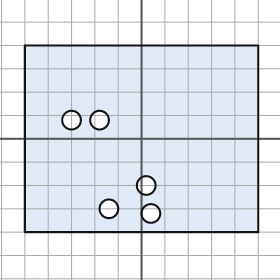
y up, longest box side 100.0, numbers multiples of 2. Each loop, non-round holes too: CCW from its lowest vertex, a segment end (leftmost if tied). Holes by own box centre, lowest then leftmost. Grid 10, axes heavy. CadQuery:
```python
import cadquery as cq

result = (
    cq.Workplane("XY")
    .moveTo(-50.0, -40.0)
    .lineTo(50.0, -40.0)
    .lineTo(50.0, 40.0)
    .lineTo(-50.0, 40.0)
    .close()
    .moveTo(4.0, -32.0)
    .circle(4.0)
    .moveTo(-14.0, -30.0)
    .circle(4.0)
    .moveTo(2.0, -20.0)
    .circle(4.0)
    .moveTo(-30.0, 8.0)
    .circle(4.0)
    .moveTo(-18.0, 8.0)
    .circle(4.0)
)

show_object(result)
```